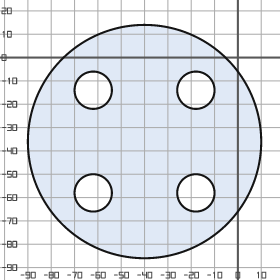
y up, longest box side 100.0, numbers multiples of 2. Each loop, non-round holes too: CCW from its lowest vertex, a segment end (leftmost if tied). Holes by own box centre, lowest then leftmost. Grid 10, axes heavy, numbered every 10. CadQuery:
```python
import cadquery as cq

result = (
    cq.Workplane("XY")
    .moveTo(-40.0, -36.0)
    .circle(50.0)
    .moveTo(-62.0, -58.0)
    .circle(8.0)
    .moveTo(-18.0, -58.0)
    .circle(8.0)
    .moveTo(-62.0, -14.0)
    .circle(8.0)
    .moveTo(-18.0, -14.0)
    .circle(8.0)
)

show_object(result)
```